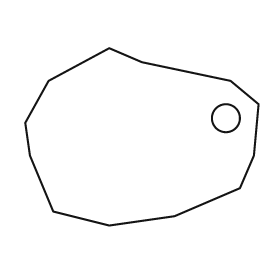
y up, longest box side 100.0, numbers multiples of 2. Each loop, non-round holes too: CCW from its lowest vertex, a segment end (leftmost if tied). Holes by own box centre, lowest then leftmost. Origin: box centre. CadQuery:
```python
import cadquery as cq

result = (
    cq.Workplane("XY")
    .moveTo(-14.0, -38.0)
    .lineTo(14.0, -34.0)
    .lineTo(42.0, -22.0)
    .lineTo(48.0, -8.0)
    .lineTo(50.0, 14.0)
    .lineTo(38.0, 24.0)
    .lineTo(0.0, 32.0)
    .lineTo(-14.0, 38.0)
    .lineTo(-40.0, 24.0)
    .lineTo(-50.0, 6.0)
    .lineTo(-48.0, -8.0)
    .lineTo(-38.0, -32.0)
    .close()
    .moveTo(36.0, 8.0)
    .circle(6.0)
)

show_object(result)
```